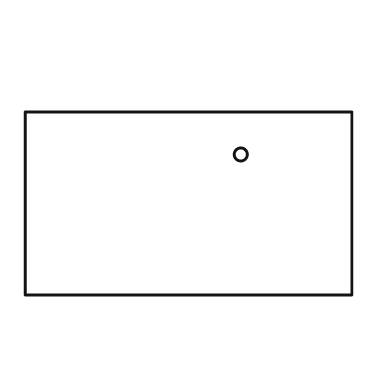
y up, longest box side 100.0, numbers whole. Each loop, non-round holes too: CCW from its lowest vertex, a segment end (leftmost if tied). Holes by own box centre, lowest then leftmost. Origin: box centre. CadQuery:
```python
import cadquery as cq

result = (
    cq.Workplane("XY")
    .moveTo(-50.0, -28.0)
    .lineTo(50.0, -28.0)
    .lineTo(50.0, 28.0)
    .lineTo(-50.0, 28.0)
    .close()
    .moveTo(16.0, 15.0)
    .circle(2.0)
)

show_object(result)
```